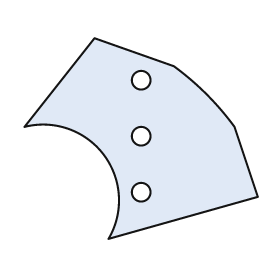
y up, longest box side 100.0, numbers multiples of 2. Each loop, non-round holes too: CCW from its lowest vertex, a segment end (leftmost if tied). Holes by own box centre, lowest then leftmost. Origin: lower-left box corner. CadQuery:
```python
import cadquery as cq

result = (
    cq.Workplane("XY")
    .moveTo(36.0, 0.0)
    .lineTo(100.0, 18.0)
    .lineTo(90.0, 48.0)
    .threePointArc((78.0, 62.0), (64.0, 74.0))
    .lineTo(30.0, 86.0)
    .lineTo(0.0, 48.0)
    .threePointArc((34.0, 36.0), (36.0, 0.0))
    .close()
    .moveTo(50.0, 20.0)
    .circle(4.0)
    .moveTo(50.0, 44.0)
    .circle(4.0)
    .moveTo(50.0, 68.0)
    .circle(4.0)
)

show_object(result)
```